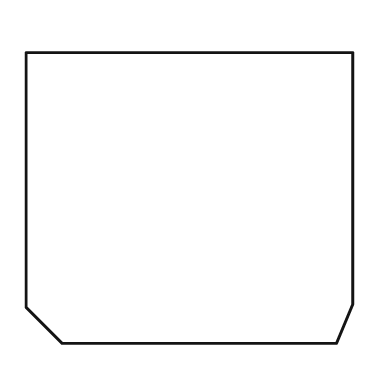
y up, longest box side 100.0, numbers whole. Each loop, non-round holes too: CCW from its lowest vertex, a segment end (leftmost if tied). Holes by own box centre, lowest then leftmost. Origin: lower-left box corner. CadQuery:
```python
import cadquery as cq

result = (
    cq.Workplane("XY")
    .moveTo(11.0, 0.0)
    .lineTo(95.0, 0.0)
    .lineTo(100.0, 12.0)
    .lineTo(100.0, 89.0)
    .lineTo(0.0, 89.0)
    .lineTo(0.0, 11.0)
    .close()
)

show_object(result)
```